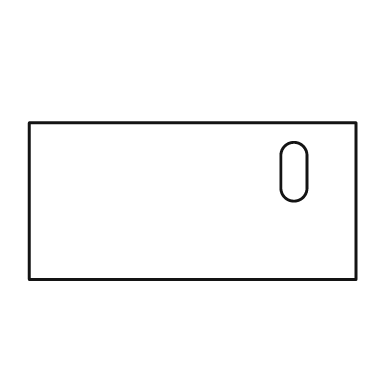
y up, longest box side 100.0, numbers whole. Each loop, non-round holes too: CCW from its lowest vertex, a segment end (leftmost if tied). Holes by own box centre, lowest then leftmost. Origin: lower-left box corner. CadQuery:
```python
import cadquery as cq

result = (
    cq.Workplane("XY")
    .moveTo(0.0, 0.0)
    .lineTo(100.0, 0.0)
    .lineTo(100.0, 48.0)
    .lineTo(0.0, 48.0)
    .close()
    .moveTo(77.0, 28.0)
    .threePointArc((81.0, 24.0), (85.0, 28.0))
    .lineTo(85.0, 38.0)
    .threePointArc((81.0, 42.0), (77.0, 38.0))
    .close()
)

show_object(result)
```